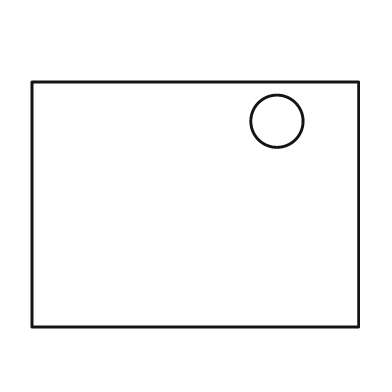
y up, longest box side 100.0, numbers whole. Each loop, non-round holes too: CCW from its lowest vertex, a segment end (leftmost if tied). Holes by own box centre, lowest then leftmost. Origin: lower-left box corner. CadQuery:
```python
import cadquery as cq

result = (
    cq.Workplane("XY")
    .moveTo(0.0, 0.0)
    .lineTo(100.0, 0.0)
    .lineTo(100.0, 75.0)
    .lineTo(0.0, 75.0)
    .close()
    .moveTo(75.0, 63.0)
    .circle(8.0)
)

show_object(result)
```